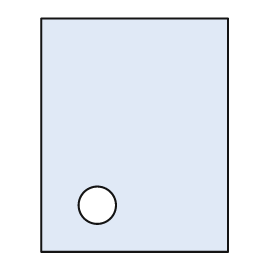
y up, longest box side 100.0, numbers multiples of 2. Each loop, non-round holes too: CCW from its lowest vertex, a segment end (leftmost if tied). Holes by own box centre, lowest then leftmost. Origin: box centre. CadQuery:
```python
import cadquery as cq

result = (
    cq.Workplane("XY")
    .moveTo(-40.0, -50.0)
    .lineTo(40.0, -50.0)
    .lineTo(40.0, 50.0)
    .lineTo(-40.0, 50.0)
    .close()
    .moveTo(-16.0, -30.0)
    .circle(8.0)
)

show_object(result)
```